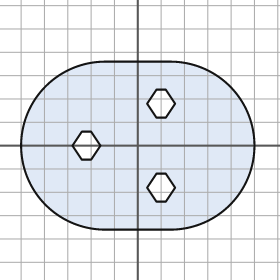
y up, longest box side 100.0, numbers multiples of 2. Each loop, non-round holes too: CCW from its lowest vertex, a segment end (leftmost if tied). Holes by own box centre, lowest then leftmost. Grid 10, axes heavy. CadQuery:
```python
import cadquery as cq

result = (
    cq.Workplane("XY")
    .moveTo(-14.0, -36.0)
    .lineTo(14.0, -36.0)
    .threePointArc((50.0, 0.0), (14.0, 36.0))
    .lineTo(-14.0, 36.0)
    .threePointArc((-50.0, 0.0), (-14.0, -36.0))
    .close()
    .moveTo(8.0, -24.0)
    .lineTo(12.0, -24.0)
    .lineTo(16.0, -18.0)
    .lineTo(12.0, -12.0)
    .lineTo(8.0, -12.0)
    .lineTo(4.0, -18.0)
    .close()
    .moveTo(-24.0, -6.0)
    .lineTo(-20.0, -6.0)
    .lineTo(-16.0, 0.0)
    .lineTo(-20.0, 6.0)
    .lineTo(-24.0, 6.0)
    .lineTo(-28.0, 0.0)
    .close()
    .moveTo(8.0, 12.0)
    .lineTo(12.0, 12.0)
    .lineTo(16.0, 18.0)
    .lineTo(12.0, 24.0)
    .lineTo(8.0, 24.0)
    .lineTo(4.0, 18.0)
    .close()
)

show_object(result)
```